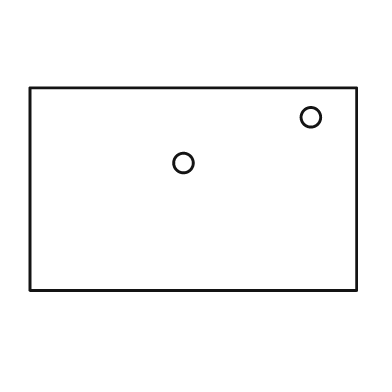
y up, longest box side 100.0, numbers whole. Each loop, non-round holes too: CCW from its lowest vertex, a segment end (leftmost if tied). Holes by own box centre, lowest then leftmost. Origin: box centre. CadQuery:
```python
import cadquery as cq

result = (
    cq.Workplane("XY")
    .moveTo(-50.0, -31.0)
    .lineTo(50.0, -31.0)
    .lineTo(50.0, 31.0)
    .lineTo(-50.0, 31.0)
    .close()
    .moveTo(-3.0, 8.0)
    .circle(3.0)
    .moveTo(36.0, 22.0)
    .circle(3.0)
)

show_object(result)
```